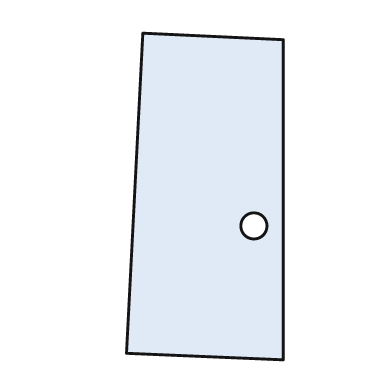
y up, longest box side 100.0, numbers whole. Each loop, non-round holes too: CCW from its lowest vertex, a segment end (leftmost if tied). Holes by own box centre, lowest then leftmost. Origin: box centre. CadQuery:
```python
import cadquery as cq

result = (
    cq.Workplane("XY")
    .moveTo(24.0, -50.0)
    .lineTo(24.0, 48.0)
    .lineTo(-19.0, 50.0)
    .lineTo(-24.0, -48.0)
    .close()
    .moveTo(15.0, -9.0)
    .circle(4.0)
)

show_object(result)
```